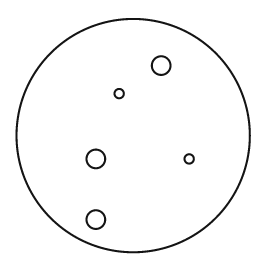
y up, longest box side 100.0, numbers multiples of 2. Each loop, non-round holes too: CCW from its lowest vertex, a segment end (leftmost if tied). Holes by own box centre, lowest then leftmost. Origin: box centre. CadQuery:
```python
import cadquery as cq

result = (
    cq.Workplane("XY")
    .moveTo(0.0, 0.0)
    .circle(50.0)
    .moveTo(-16.0, -36.0)
    .circle(4.0)
    .moveTo(-16.0, -10.0)
    .circle(4.0)
    .moveTo(24.0, -10.0)
    .circle(2.0)
    .moveTo(-6.0, 18.0)
    .circle(2.0)
    .moveTo(12.0, 30.0)
    .circle(4.0)
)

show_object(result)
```